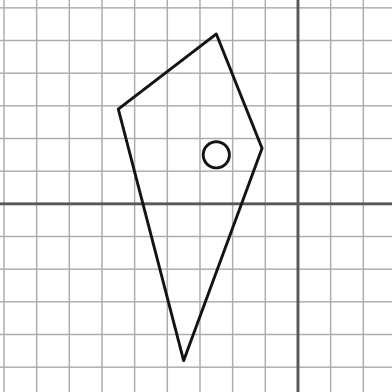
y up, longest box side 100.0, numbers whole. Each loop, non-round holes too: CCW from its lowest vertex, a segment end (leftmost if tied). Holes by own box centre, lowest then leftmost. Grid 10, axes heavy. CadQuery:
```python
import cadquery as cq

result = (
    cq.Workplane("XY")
    .moveTo(-35.0, -48.0)
    .lineTo(-11.0, 17.0)
    .lineTo(-25.0, 52.0)
    .lineTo(-55.0, 29.0)
    .close()
    .moveTo(-25.0, 15.0)
    .circle(4.0)
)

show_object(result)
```